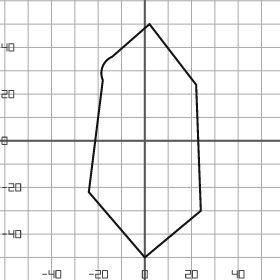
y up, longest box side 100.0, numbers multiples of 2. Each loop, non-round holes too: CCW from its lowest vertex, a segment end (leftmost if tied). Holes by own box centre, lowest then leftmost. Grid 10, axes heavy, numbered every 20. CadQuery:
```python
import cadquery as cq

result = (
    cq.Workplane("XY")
    .moveTo(0.0, -50.0)
    .lineTo(24.0, -30.0)
    .lineTo(22.0, 24.0)
    .lineTo(2.0, 50.0)
    .lineTo(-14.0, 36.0)
    .threePointArc((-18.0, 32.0), (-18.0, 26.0))
    .lineTo(-24.0, -22.0)
    .close()
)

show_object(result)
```